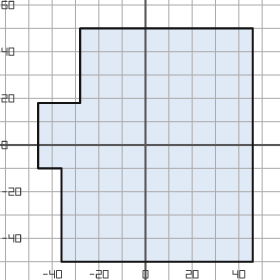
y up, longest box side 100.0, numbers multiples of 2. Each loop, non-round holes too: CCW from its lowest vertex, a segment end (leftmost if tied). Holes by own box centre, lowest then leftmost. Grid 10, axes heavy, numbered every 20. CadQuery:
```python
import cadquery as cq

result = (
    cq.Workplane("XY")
    .moveTo(-36.0, -50.0)
    .lineTo(46.0, -50.0)
    .lineTo(46.0, 50.0)
    .lineTo(-28.0, 50.0)
    .lineTo(-28.0, 18.0)
    .lineTo(-46.0, 18.0)
    .lineTo(-46.0, -10.0)
    .lineTo(-36.0, -10.0)
    .close()
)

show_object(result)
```